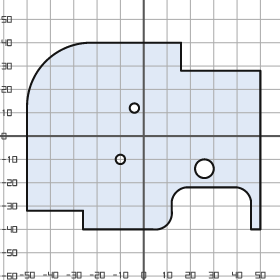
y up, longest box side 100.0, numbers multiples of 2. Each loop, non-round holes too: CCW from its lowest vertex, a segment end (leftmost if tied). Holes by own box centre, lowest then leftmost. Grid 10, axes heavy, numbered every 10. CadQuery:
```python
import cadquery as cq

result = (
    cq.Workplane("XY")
    .moveTo(-26.0, -40.0)
    .lineTo(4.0, -40.0)
    .threePointArc((10.0, -38.0), (12.0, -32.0))
    .lineTo(12.0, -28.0)
    .threePointArc((14.0, -24.0), (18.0, -22.0))
    .lineTo(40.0, -22.0)
    .threePointArc((44.0, -24.0), (46.0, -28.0))
    .lineTo(46.0, -40.0)
    .lineTo(50.0, -40.0)
    .lineTo(50.0, 28.0)
    .lineTo(16.0, 28.0)
    .lineTo(16.0, 40.0)
    .lineTo(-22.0, 40.0)
    .threePointArc((-42.0, 32.0), (-50.0, 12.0))
    .lineTo(-50.0, -32.0)
    .lineTo(-26.0, -32.0)
    .close()
    .moveTo(26.0, -14.0)
    .circle(4.0)
    .moveTo(-10.0, -10.0)
    .circle(2.0)
    .moveTo(-4.0, 12.0)
    .circle(2.0)
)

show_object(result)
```